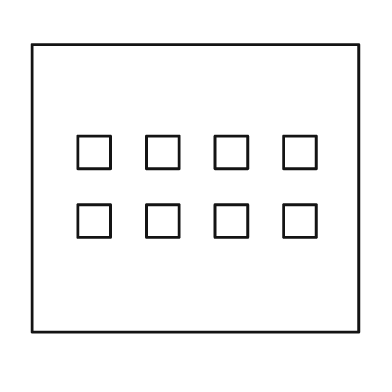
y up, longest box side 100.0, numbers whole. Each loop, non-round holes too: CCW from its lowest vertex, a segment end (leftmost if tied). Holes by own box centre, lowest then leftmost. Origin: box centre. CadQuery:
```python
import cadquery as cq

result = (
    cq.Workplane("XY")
    .moveTo(-50.0, -44.0)
    .lineTo(50.0, -44.0)
    .lineTo(50.0, 44.0)
    .lineTo(-50.0, 44.0)
    .close()
    .moveTo(-36.0, -15.0)
    .lineTo(-26.0, -15.0)
    .lineTo(-26.0, -5.0)
    .lineTo(-36.0, -5.0)
    .close()
    .moveTo(-15.0, -15.0)
    .lineTo(-5.0, -15.0)
    .lineTo(-5.0, -5.0)
    .lineTo(-15.0, -5.0)
    .close()
    .moveTo(6.0, -15.0)
    .lineTo(16.0, -15.0)
    .lineTo(16.0, -5.0)
    .lineTo(6.0, -5.0)
    .close()
    .moveTo(27.0, -15.0)
    .lineTo(37.0, -15.0)
    .lineTo(37.0, -5.0)
    .lineTo(27.0, -5.0)
    .close()
    .moveTo(-36.0, 6.0)
    .lineTo(-26.0, 6.0)
    .lineTo(-26.0, 16.0)
    .lineTo(-36.0, 16.0)
    .close()
    .moveTo(-15.0, 6.0)
    .lineTo(-5.0, 6.0)
    .lineTo(-5.0, 16.0)
    .lineTo(-15.0, 16.0)
    .close()
    .moveTo(6.0, 6.0)
    .lineTo(16.0, 6.0)
    .lineTo(16.0, 16.0)
    .lineTo(6.0, 16.0)
    .close()
    .moveTo(27.0, 6.0)
    .lineTo(37.0, 6.0)
    .lineTo(37.0, 16.0)
    .lineTo(27.0, 16.0)
    .close()
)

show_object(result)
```